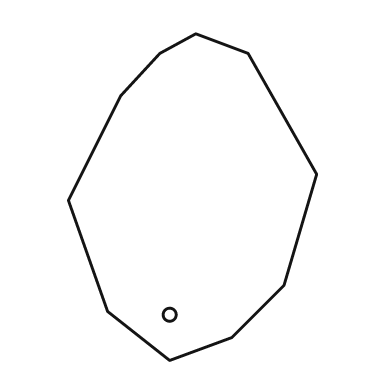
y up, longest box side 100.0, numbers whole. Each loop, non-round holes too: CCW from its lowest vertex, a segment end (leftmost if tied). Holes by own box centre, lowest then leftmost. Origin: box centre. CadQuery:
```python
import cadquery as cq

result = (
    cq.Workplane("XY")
    .moveTo(-7.0, -50.0)
    .lineTo(12.0, -43.0)
    .lineTo(28.0, -27.0)
    .lineTo(38.0, 7.0)
    .lineTo(17.0, 44.0)
    .lineTo(1.0, 50.0)
    .lineTo(-10.0, 44.0)
    .lineTo(-22.0, 31.0)
    .lineTo(-38.0, -1.0)
    .lineTo(-26.0, -35.0)
    .close()
    .moveTo(-7.0, -36.0)
    .circle(2.0)
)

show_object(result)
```